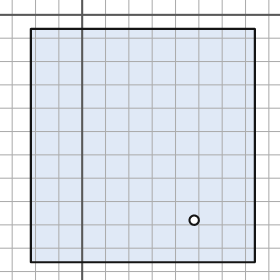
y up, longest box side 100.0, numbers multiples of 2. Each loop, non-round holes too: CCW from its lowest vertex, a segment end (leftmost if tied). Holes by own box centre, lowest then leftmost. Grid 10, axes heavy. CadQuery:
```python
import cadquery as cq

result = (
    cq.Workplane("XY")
    .moveTo(-22.0, -106.0)
    .lineTo(74.0, -106.0)
    .lineTo(74.0, -6.0)
    .lineTo(-22.0, -6.0)
    .close()
    .moveTo(48.0, -88.0)
    .circle(2.0)
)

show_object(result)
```